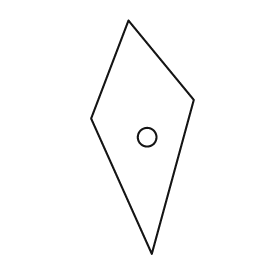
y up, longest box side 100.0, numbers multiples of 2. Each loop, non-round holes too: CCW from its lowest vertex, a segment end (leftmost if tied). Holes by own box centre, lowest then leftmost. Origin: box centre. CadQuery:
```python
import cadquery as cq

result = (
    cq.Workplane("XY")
    .moveTo(4.0, -50.0)
    .lineTo(22.0, 16.0)
    .lineTo(-6.0, 50.0)
    .lineTo(-22.0, 8.0)
    .close()
    .moveTo(2.0, 0.0)
    .circle(4.0)
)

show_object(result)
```